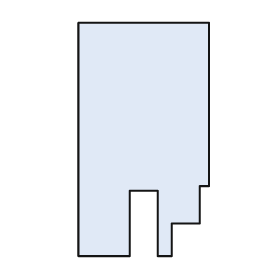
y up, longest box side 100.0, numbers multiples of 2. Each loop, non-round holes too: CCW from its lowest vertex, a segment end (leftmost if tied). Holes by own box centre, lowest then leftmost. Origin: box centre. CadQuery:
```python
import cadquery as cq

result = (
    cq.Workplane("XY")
    .moveTo(-28.0, -50.0)
    .lineTo(-6.0, -50.0)
    .lineTo(-6.0, -22.0)
    .lineTo(6.0, -22.0)
    .lineTo(6.0, -50.0)
    .lineTo(12.0, -50.0)
    .lineTo(12.0, -36.0)
    .lineTo(24.0, -36.0)
    .lineTo(24.0, -20.0)
    .lineTo(28.0, -20.0)
    .lineTo(28.0, 50.0)
    .lineTo(-28.0, 50.0)
    .close()
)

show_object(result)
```